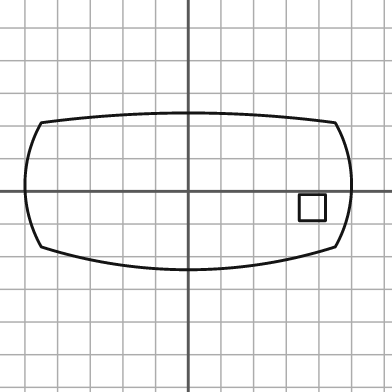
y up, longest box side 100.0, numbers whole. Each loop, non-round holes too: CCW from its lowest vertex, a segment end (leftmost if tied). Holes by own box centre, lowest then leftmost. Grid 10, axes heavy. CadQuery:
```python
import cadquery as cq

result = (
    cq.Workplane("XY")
    .moveTo(-45.0, -17.0)
    .threePointArc((0.0, -24.0), (45.0, -17.0))
    .threePointArc((50.0, 2.0), (45.0, 21.0))
    .threePointArc((0.0, 24.0), (-45.0, 21.0))
    .threePointArc((-50.0, 2.0), (-45.0, -17.0))
    .close()
    .moveTo(34.0, -9.0)
    .lineTo(42.0, -9.0)
    .lineTo(42.0, -1.0)
    .lineTo(34.0, -1.0)
    .close()
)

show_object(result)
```